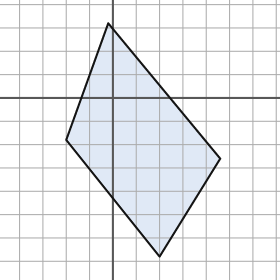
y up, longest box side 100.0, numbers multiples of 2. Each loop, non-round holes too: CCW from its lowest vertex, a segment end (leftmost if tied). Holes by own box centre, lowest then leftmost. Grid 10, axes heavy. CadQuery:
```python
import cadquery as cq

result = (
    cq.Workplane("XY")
    .moveTo(20.0, -68.0)
    .lineTo(46.0, -26.0)
    .lineTo(-2.0, 32.0)
    .lineTo(-20.0, -18.0)
    .close()
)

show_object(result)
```